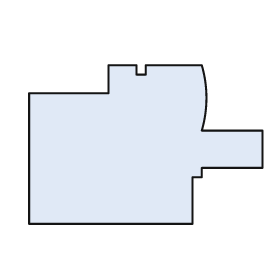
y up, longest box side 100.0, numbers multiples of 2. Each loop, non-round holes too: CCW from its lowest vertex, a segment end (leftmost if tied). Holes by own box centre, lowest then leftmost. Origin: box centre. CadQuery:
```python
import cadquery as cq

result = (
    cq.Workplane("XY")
    .moveTo(-50.0, -34.0)
    .lineTo(20.0, -34.0)
    .lineTo(20.0, -14.0)
    .lineTo(24.0, -14.0)
    .lineTo(24.0, -10.0)
    .lineTo(50.0, -10.0)
    .lineTo(50.0, 6.0)
    .lineTo(24.0, 6.0)
    .threePointArc((26.0, 20.0), (24.0, 34.0))
    .lineTo(0.0, 34.0)
    .lineTo(0.0, 30.0)
    .lineTo(-4.0, 30.0)
    .lineTo(-4.0, 34.0)
    .lineTo(-16.0, 34.0)
    .lineTo(-16.0, 22.0)
    .lineTo(-50.0, 22.0)
    .close()
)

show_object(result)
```